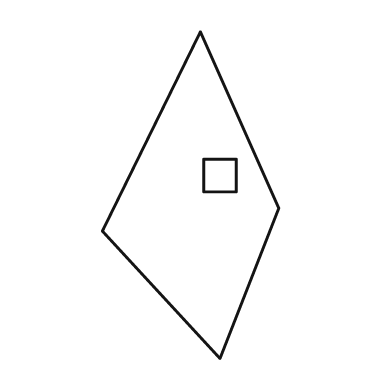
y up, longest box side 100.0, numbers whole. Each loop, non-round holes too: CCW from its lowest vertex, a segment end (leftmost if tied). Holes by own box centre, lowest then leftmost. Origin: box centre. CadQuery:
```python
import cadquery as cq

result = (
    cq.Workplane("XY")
    .moveTo(9.0, -50.0)
    .lineTo(27.0, -4.0)
    .lineTo(3.0, 50.0)
    .lineTo(-27.0, -11.0)
    .close()
    .moveTo(4.0, 1.0)
    .lineTo(14.0, 1.0)
    .lineTo(14.0, 11.0)
    .lineTo(4.0, 11.0)
    .close()
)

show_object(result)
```